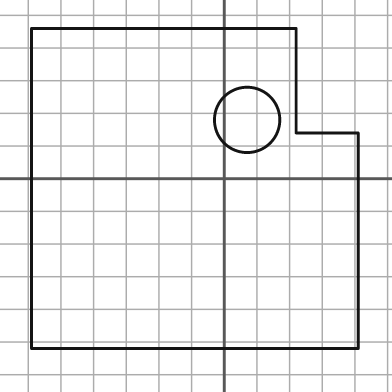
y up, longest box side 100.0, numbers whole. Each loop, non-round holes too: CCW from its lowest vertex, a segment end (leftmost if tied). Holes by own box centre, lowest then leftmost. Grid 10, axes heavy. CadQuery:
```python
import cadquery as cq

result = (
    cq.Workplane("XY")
    .moveTo(-59.0, -52.0)
    .lineTo(41.0, -52.0)
    .lineTo(41.0, 14.0)
    .lineTo(22.0, 14.0)
    .lineTo(22.0, 46.0)
    .lineTo(-59.0, 46.0)
    .close()
    .moveTo(7.0, 18.0)
    .circle(10.0)
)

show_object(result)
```